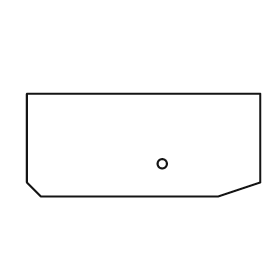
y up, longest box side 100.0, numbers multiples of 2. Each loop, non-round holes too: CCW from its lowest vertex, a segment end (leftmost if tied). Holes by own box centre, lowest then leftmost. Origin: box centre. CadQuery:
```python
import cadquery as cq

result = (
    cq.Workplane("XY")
    .moveTo(-44.0, -22.0)
    .lineTo(32.0, -22.0)
    .lineTo(50.0, -16.0)
    .lineTo(50.0, 22.0)
    .lineTo(-50.0, 22.0)
    .lineTo(-50.0, -16.0)
    .close()
    .moveTo(8.0, -8.0)
    .circle(2.0)
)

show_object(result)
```